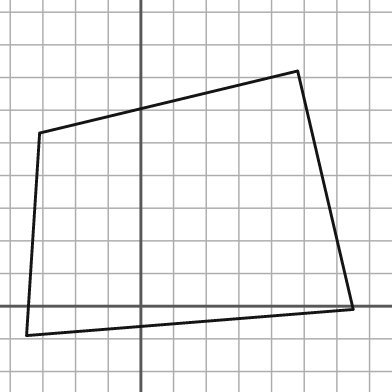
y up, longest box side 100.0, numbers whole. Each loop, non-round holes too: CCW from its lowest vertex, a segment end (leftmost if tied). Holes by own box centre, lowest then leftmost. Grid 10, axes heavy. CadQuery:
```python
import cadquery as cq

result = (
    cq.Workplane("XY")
    .moveTo(-35.0, -9.0)
    .lineTo(65.0, -1.0)
    .lineTo(48.0, 72.0)
    .lineTo(-31.0, 53.0)
    .close()
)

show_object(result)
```